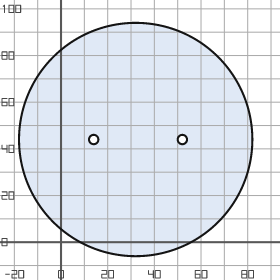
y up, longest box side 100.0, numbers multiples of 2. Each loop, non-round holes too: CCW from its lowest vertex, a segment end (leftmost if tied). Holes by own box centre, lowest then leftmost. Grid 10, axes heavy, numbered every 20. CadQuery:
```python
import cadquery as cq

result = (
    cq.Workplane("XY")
    .moveTo(32.0, 44.0)
    .circle(50.0)
    .moveTo(14.0, 44.0)
    .circle(2.0)
    .moveTo(52.0, 44.0)
    .circle(2.0)
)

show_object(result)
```